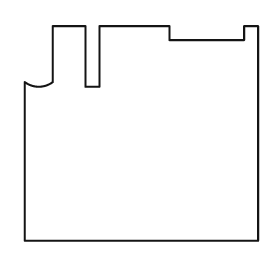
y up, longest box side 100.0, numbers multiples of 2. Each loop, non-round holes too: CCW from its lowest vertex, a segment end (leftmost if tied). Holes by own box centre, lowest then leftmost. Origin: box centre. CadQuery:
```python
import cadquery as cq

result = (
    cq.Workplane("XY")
    .moveTo(-50.0, -46.0)
    .lineTo(50.0, -46.0)
    .lineTo(50.0, 46.0)
    .lineTo(44.0, 46.0)
    .lineTo(44.0, 40.0)
    .lineTo(12.0, 40.0)
    .lineTo(12.0, 46.0)
    .lineTo(-18.0, 46.0)
    .lineTo(-18.0, 20.0)
    .lineTo(-24.0, 20.0)
    .lineTo(-24.0, 46.0)
    .lineTo(-38.0, 46.0)
    .lineTo(-38.0, 22.0)
    .threePointArc((-44.0, 20.0), (-50.0, 22.0))
    .close()
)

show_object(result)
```